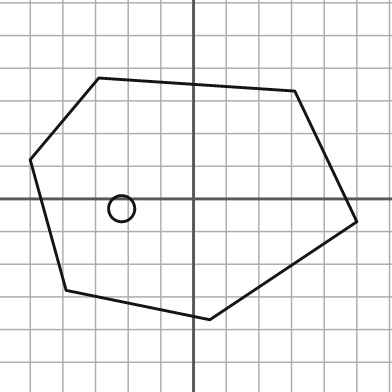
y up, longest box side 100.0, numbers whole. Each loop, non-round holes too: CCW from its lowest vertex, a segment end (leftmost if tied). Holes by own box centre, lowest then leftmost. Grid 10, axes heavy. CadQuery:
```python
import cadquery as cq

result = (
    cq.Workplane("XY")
    .moveTo(5.0, -37.0)
    .lineTo(50.0, -7.0)
    .lineTo(31.0, 33.0)
    .lineTo(-29.0, 37.0)
    .lineTo(-50.0, 12.0)
    .lineTo(-39.0, -28.0)
    .close()
    .moveTo(-22.0, -3.0)
    .circle(4.0)
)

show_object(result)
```